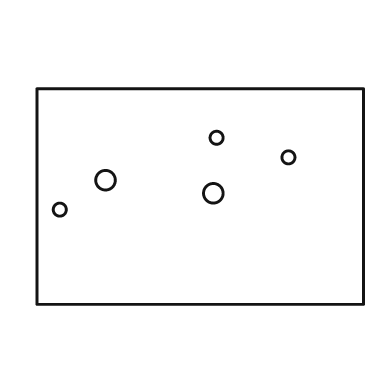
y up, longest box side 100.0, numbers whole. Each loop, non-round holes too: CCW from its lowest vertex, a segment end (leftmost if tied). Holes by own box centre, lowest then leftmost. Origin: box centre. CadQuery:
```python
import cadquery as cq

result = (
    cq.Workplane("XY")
    .moveTo(-50.0, -33.0)
    .lineTo(50.0, -33.0)
    .lineTo(50.0, 33.0)
    .lineTo(-50.0, 33.0)
    .close()
    .moveTo(-43.0, -4.0)
    .circle(2.0)
    .moveTo(4.0, 1.0)
    .circle(3.0)
    .moveTo(-29.0, 5.0)
    .circle(3.0)
    .moveTo(27.0, 12.0)
    .circle(2.0)
    .moveTo(5.0, 18.0)
    .circle(2.0)
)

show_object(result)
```